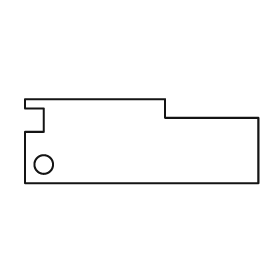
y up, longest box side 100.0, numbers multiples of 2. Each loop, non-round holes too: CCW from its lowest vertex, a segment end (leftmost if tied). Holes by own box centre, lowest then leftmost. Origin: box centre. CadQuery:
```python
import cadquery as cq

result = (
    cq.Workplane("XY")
    .moveTo(-50.0, -18.0)
    .lineTo(50.0, -18.0)
    .lineTo(50.0, 10.0)
    .lineTo(10.0, 10.0)
    .lineTo(10.0, 18.0)
    .lineTo(-50.0, 18.0)
    .lineTo(-50.0, 14.0)
    .lineTo(-42.0, 14.0)
    .lineTo(-42.0, 4.0)
    .lineTo(-50.0, 4.0)
    .close()
    .moveTo(-42.0, -10.0)
    .circle(4.0)
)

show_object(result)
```